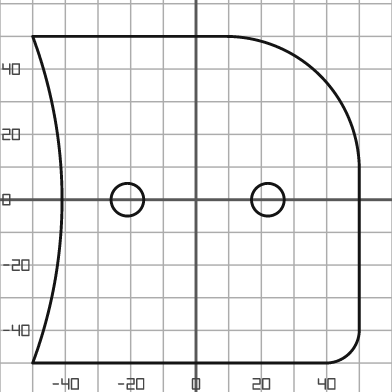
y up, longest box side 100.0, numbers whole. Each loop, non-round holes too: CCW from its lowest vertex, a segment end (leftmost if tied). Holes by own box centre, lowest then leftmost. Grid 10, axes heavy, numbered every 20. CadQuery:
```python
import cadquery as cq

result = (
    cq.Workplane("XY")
    .moveTo(-50.0, -50.0)
    .lineTo(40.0, -50.0)
    .threePointArc((47.0, -47.0), (50.0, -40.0))
    .lineTo(50.0, 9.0)
    .threePointArc((38.0, 38.0), (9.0, 50.0))
    .lineTo(-50.0, 50.0)
    .threePointArc((-41.0, 0.0), (-50.0, -50.0))
    .close()
    .moveTo(-21.0, 0.0)
    .circle(5.0)
    .moveTo(22.0, 0.0)
    .circle(5.0)
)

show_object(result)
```